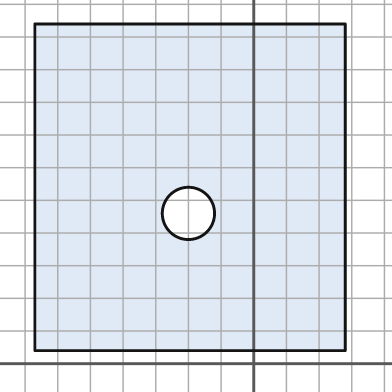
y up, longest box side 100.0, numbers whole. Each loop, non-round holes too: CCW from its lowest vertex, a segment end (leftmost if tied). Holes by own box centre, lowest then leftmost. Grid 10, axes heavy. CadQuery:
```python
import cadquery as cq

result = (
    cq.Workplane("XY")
    .moveTo(-67.0, 4.0)
    .lineTo(28.0, 4.0)
    .lineTo(28.0, 104.0)
    .lineTo(-67.0, 104.0)
    .close()
    .moveTo(-20.0, 46.0)
    .circle(8.0)
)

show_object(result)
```